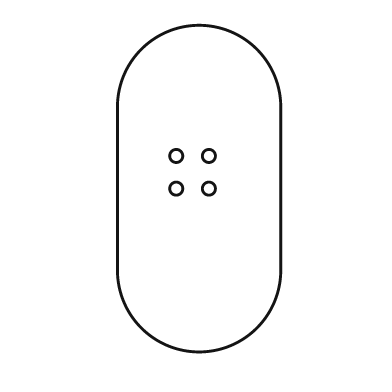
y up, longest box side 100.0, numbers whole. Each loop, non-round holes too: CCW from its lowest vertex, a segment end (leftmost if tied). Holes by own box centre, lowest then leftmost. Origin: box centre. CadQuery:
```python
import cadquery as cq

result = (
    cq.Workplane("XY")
    .moveTo(-25.0, -25.0)
    .threePointArc((0.0, -50.0), (25.0, -25.0))
    .lineTo(25.0, 25.0)
    .threePointArc((0.0, 50.0), (-25.0, 25.0))
    .close()
    .moveTo(-7.0, 0.0)
    .circle(2.0)
    .moveTo(3.0, 0.0)
    .circle(2.0)
    .moveTo(-7.0, 10.0)
    .circle(2.0)
    .moveTo(3.0, 10.0)
    .circle(2.0)
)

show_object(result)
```